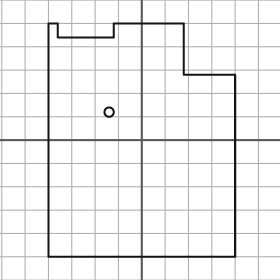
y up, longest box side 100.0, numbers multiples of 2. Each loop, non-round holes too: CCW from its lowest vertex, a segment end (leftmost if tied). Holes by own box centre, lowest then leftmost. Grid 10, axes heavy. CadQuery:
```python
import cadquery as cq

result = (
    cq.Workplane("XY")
    .moveTo(-40.0, -50.0)
    .lineTo(40.0, -50.0)
    .lineTo(40.0, 28.0)
    .lineTo(18.0, 28.0)
    .lineTo(18.0, 50.0)
    .lineTo(-12.0, 50.0)
    .lineTo(-12.0, 44.0)
    .lineTo(-36.0, 44.0)
    .lineTo(-36.0, 50.0)
    .lineTo(-40.0, 50.0)
    .close()
    .moveTo(-14.0, 12.0)
    .circle(2.0)
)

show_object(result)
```